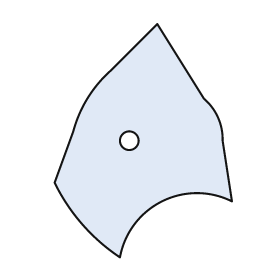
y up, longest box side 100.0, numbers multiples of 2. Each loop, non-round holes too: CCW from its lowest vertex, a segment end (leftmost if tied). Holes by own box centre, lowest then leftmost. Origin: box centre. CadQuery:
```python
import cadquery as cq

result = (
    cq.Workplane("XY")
    .moveTo(-10.0, -50.0)
    .threePointArc((8.0, -26.0), (38.0, -26.0))
    .lineTo(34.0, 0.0)
    .threePointArc((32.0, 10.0), (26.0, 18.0))
    .lineTo(6.0, 50.0)
    .lineTo(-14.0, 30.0)
    .threePointArc((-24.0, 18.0), (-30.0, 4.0))
    .lineTo(-38.0, -18.0)
    .threePointArc((-26.0, -36.0), (-10.0, -50.0))
    .close()
    .moveTo(-6.0, 0.0)
    .circle(4.0)
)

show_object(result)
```